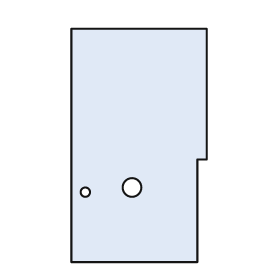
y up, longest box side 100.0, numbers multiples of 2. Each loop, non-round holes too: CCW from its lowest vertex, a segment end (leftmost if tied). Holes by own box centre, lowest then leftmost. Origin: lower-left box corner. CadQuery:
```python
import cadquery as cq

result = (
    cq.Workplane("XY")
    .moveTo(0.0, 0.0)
    .lineTo(54.0, 0.0)
    .lineTo(54.0, 44.0)
    .lineTo(58.0, 44.0)
    .lineTo(58.0, 100.0)
    .lineTo(0.0, 100.0)
    .close()
    .moveTo(6.0, 30.0)
    .circle(2.0)
    .moveTo(26.0, 32.0)
    .circle(4.0)
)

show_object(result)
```